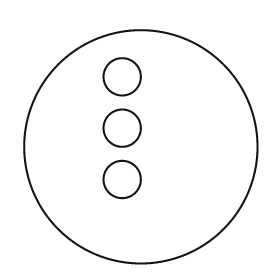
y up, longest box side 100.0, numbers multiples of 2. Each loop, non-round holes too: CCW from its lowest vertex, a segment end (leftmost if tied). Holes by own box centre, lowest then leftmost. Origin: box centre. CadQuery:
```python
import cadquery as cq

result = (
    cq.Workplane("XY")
    .moveTo(0.0, 0.0)
    .circle(50.0)
    .moveTo(-8.0, -14.0)
    .circle(8.0)
    .moveTo(-8.0, 8.0)
    .circle(8.0)
    .moveTo(-8.0, 30.0)
    .circle(8.0)
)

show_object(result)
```